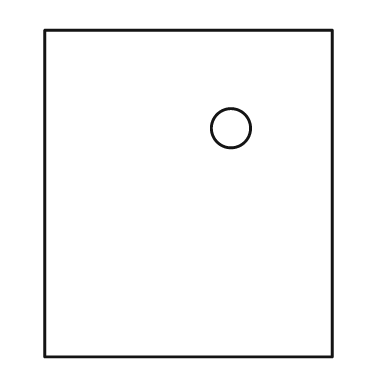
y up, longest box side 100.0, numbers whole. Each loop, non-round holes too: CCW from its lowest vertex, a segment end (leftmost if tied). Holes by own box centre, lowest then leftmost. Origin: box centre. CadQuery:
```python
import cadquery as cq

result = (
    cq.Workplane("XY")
    .moveTo(-44.0, -50.0)
    .lineTo(44.0, -50.0)
    .lineTo(44.0, 50.0)
    .lineTo(-44.0, 50.0)
    .close()
    .moveTo(13.0, 20.0)
    .circle(6.0)
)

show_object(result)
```